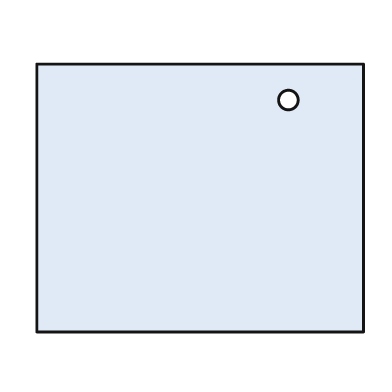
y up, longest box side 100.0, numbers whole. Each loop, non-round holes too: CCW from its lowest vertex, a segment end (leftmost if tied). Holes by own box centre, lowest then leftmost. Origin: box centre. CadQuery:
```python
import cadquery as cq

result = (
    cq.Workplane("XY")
    .moveTo(-50.0, -41.0)
    .lineTo(50.0, -41.0)
    .lineTo(50.0, 41.0)
    .lineTo(-50.0, 41.0)
    .close()
    .moveTo(27.0, 30.0)
    .circle(3.0)
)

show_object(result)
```